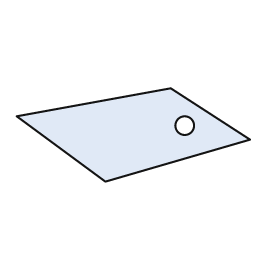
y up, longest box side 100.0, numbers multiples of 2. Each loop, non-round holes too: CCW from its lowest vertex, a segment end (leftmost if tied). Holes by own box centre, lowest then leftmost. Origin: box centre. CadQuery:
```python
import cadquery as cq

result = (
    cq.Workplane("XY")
    .moveTo(-12.0, -20.0)
    .lineTo(50.0, -2.0)
    .lineTo(16.0, 20.0)
    .lineTo(-50.0, 8.0)
    .close()
    .moveTo(22.0, 4.0)
    .circle(4.0)
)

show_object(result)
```